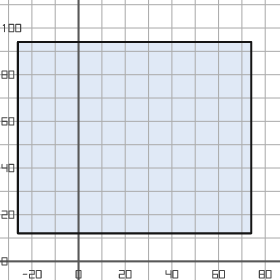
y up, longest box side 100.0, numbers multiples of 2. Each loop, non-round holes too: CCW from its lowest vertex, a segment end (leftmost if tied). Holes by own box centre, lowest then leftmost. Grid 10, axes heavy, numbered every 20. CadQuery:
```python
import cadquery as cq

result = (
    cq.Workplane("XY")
    .moveTo(-26.0, 12.0)
    .lineTo(74.0, 12.0)
    .lineTo(74.0, 94.0)
    .lineTo(-26.0, 94.0)
    .close()
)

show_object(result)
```